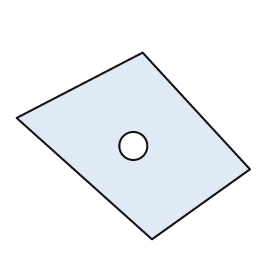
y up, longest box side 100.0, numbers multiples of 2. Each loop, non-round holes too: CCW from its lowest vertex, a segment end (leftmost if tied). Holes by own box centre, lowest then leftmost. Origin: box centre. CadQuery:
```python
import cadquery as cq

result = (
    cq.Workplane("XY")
    .moveTo(8.0, -40.0)
    .lineTo(50.0, -10.0)
    .lineTo(4.0, 40.0)
    .lineTo(-50.0, 12.0)
    .close()
    .moveTo(0.0, 0.0)
    .circle(6.0)
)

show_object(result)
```